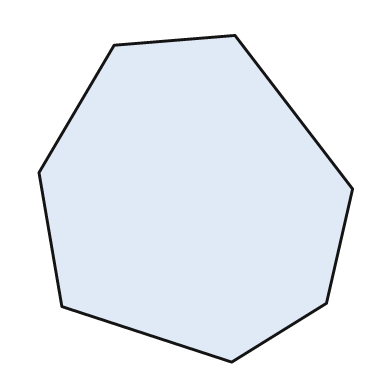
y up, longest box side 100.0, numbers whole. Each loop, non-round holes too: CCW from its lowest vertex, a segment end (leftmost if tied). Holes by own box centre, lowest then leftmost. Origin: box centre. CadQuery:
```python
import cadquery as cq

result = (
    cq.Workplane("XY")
    .moveTo(11.0, -50.0)
    .lineTo(40.0, -32.0)
    .lineTo(48.0, 3.0)
    .lineTo(12.0, 50.0)
    .lineTo(-25.0, 47.0)
    .lineTo(-48.0, 8.0)
    .lineTo(-41.0, -33.0)
    .close()
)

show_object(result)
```